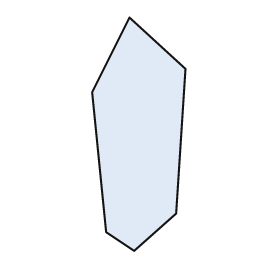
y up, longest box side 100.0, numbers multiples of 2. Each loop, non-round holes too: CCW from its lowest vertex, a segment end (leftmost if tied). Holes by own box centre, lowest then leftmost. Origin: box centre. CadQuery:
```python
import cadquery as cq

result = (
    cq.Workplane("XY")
    .moveTo(-2.0, -50.0)
    .lineTo(16.0, -34.0)
    .lineTo(20.0, 28.0)
    .lineTo(-4.0, 50.0)
    .lineTo(-20.0, 18.0)
    .lineTo(-14.0, -42.0)
    .close()
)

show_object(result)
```